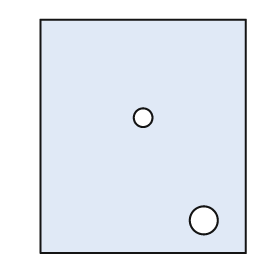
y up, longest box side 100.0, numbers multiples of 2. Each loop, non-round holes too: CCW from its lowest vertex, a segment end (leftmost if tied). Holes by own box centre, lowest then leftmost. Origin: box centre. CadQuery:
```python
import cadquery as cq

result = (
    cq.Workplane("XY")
    .moveTo(-44.0, -50.0)
    .lineTo(44.0, -50.0)
    .lineTo(44.0, 50.0)
    .lineTo(-44.0, 50.0)
    .close()
    .moveTo(26.0, -36.0)
    .circle(6.0)
    .moveTo(0.0, 8.0)
    .circle(4.0)
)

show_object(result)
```